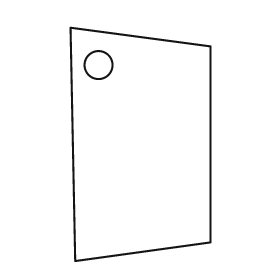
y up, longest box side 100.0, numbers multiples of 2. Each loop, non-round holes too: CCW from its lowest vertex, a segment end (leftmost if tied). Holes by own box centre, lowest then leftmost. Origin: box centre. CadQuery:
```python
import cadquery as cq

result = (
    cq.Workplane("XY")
    .moveTo(-28.0, -50.0)
    .lineTo(30.0, -42.0)
    .lineTo(30.0, 42.0)
    .lineTo(-30.0, 50.0)
    .close()
    .moveTo(-18.0, 34.0)
    .circle(6.0)
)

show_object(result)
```